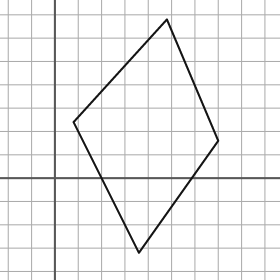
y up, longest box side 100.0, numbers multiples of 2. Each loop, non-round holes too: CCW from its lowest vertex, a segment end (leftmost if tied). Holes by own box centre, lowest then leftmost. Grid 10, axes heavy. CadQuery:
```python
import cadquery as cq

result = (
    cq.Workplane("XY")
    .moveTo(36.0, -32.0)
    .lineTo(70.0, 16.0)
    .lineTo(48.0, 68.0)
    .lineTo(8.0, 24.0)
    .close()
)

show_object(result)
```